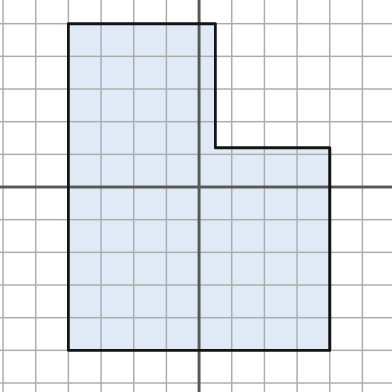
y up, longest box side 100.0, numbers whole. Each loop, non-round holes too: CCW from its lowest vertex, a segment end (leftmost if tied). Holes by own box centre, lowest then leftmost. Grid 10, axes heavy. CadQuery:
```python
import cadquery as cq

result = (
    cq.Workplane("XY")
    .moveTo(-40.0, -50.0)
    .lineTo(40.0, -50.0)
    .lineTo(40.0, 12.0)
    .lineTo(5.0, 12.0)
    .lineTo(5.0, 50.0)
    .lineTo(-40.0, 50.0)
    .close()
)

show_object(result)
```